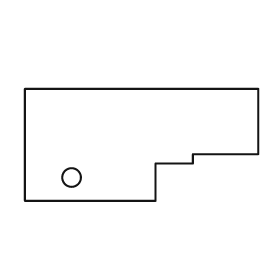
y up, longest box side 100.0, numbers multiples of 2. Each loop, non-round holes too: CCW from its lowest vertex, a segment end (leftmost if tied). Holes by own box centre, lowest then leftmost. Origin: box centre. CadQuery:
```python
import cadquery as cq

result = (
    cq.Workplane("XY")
    .moveTo(-50.0, -24.0)
    .lineTo(6.0, -24.0)
    .lineTo(6.0, -8.0)
    .lineTo(22.0, -8.0)
    .lineTo(22.0, -4.0)
    .lineTo(50.0, -4.0)
    .lineTo(50.0, 24.0)
    .lineTo(-50.0, 24.0)
    .close()
    .moveTo(-30.0, -14.0)
    .circle(4.0)
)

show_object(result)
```